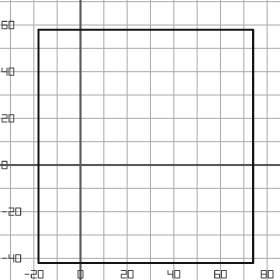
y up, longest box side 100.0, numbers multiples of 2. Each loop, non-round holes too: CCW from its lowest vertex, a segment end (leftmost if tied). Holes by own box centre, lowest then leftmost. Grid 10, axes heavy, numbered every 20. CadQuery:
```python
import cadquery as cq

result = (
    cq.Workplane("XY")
    .moveTo(-18.0, -42.0)
    .lineTo(74.0, -42.0)
    .lineTo(74.0, 58.0)
    .lineTo(-18.0, 58.0)
    .close()
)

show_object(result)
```